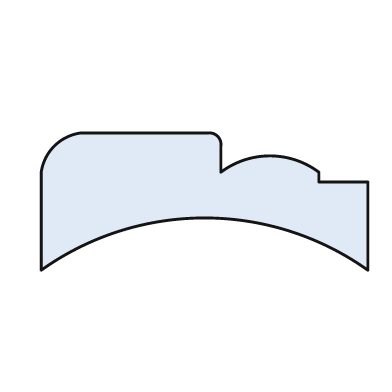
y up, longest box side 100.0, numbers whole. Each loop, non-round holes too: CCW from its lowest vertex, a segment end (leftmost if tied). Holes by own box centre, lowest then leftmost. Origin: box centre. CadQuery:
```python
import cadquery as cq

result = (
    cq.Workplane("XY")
    .moveTo(-50.0, -21.0)
    .threePointArc((0.0, -5.0), (50.0, -21.0))
    .lineTo(50.0, 6.0)
    .lineTo(35.0, 6.0)
    .lineTo(35.0, 9.0)
    .threePointArc((20.0, 14.0), (5.0, 9.0))
    .lineTo(5.0, 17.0)
    .threePointArc((4.0, 20.0), (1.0, 21.0))
    .lineTo(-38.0, 21.0)
    .threePointArc((-46.0, 17.0), (-50.0, 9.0))
    .close()
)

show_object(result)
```